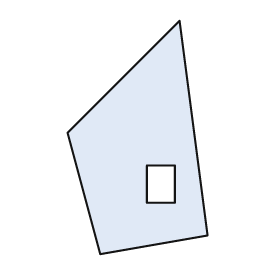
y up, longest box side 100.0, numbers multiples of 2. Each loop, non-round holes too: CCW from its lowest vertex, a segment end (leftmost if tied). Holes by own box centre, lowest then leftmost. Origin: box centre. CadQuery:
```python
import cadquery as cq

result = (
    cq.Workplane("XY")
    .moveTo(-16.0, -50.0)
    .lineTo(30.0, -42.0)
    .lineTo(18.0, 50.0)
    .lineTo(-30.0, 2.0)
    .close()
    .moveTo(4.0, -28.0)
    .lineTo(16.0, -28.0)
    .lineTo(16.0, -12.0)
    .lineTo(4.0, -12.0)
    .close()
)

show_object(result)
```